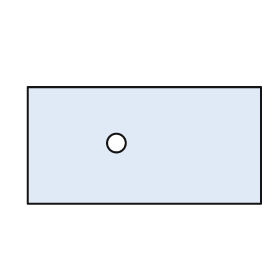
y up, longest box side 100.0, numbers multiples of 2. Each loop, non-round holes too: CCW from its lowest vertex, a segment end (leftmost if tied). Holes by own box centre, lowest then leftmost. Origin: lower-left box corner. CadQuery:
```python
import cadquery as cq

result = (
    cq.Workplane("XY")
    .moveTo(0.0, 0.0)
    .lineTo(100.0, 0.0)
    .lineTo(100.0, 50.0)
    .lineTo(0.0, 50.0)
    .close()
    .moveTo(38.0, 26.0)
    .circle(4.0)
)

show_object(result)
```